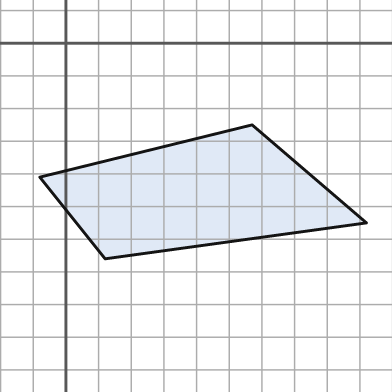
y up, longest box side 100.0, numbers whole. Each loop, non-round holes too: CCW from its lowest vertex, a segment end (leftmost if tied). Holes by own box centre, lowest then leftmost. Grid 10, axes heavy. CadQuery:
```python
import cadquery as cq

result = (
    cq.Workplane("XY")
    .moveTo(12.0, -66.0)
    .lineTo(92.0, -55.0)
    .lineTo(57.0, -25.0)
    .lineTo(-8.0, -41.0)
    .close()
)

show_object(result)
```